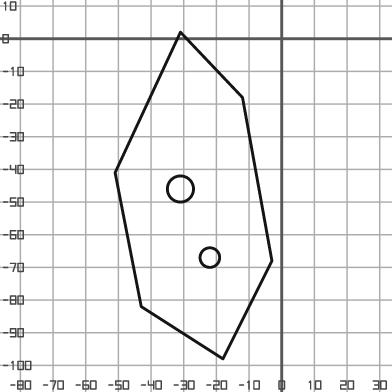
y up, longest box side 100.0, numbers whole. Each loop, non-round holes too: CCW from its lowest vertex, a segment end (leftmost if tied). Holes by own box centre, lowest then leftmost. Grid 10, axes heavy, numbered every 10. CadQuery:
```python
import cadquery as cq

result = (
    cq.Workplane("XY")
    .moveTo(-18.0, -98.0)
    .lineTo(-3.0, -68.0)
    .lineTo(-12.0, -18.0)
    .lineTo(-31.0, 2.0)
    .lineTo(-51.0, -41.0)
    .lineTo(-43.0, -82.0)
    .close()
    .moveTo(-22.0, -67.0)
    .circle(3.0)
    .moveTo(-31.0, -46.0)
    .circle(4.0)
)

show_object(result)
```